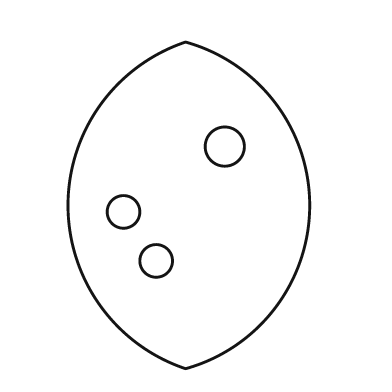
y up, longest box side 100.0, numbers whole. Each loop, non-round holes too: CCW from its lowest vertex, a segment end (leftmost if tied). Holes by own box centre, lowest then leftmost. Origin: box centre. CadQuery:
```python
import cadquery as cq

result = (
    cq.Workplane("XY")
    .moveTo(-1.0, -50.0)
    .threePointArc((37.0, 0.0), (-1.0, 50.0))
    .threePointArc((-37.0, 0.0), (-1.0, -50.0))
    .close()
    .moveTo(-10.0, -17.0)
    .circle(5.0)
    .moveTo(-20.0, -2.0)
    .circle(5.0)
    .moveTo(11.0, 18.0)
    .circle(6.0)
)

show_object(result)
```